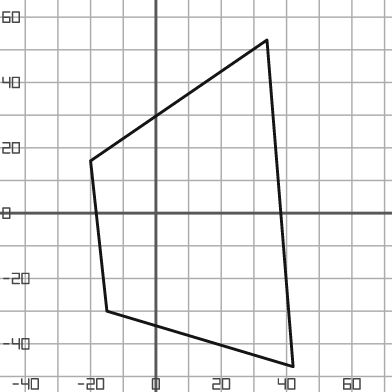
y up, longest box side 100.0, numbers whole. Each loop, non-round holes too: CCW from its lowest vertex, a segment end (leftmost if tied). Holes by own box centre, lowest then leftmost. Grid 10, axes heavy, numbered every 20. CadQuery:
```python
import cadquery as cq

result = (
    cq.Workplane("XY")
    .moveTo(42.0, -47.0)
    .lineTo(34.0, 53.0)
    .lineTo(-20.0, 16.0)
    .lineTo(-15.0, -30.0)
    .close()
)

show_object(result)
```